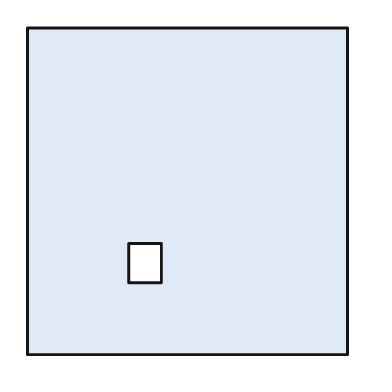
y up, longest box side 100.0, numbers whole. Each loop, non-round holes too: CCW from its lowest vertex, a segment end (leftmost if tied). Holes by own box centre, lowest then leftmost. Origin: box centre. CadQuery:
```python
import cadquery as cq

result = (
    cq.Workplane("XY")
    .moveTo(-49.0, -50.0)
    .lineTo(49.0, -50.0)
    .lineTo(49.0, 50.0)
    .lineTo(-49.0, 50.0)
    .close()
    .moveTo(-18.0, -28.0)
    .lineTo(-8.0, -28.0)
    .lineTo(-8.0, -16.0)
    .lineTo(-18.0, -16.0)
    .close()
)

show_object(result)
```